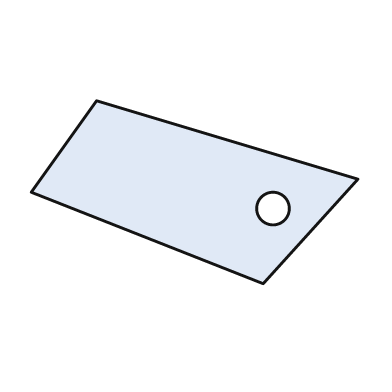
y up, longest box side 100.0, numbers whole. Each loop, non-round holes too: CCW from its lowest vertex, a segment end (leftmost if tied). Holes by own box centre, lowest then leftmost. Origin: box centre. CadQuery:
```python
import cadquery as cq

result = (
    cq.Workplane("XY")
    .moveTo(21.0, -28.0)
    .lineTo(50.0, 4.0)
    .lineTo(-30.0, 28.0)
    .lineTo(-50.0, 0.0)
    .close()
    .moveTo(24.0, -5.0)
    .circle(5.0)
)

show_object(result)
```